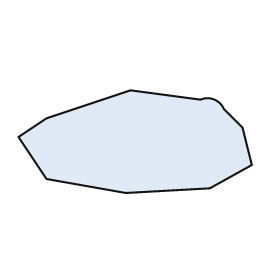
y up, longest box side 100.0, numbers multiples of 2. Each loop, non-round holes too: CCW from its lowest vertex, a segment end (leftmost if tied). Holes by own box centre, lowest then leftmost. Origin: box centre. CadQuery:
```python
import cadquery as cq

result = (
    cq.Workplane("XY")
    .moveTo(-4.0, -22.0)
    .lineTo(32.0, -20.0)
    .lineTo(50.0, -10.0)
    .lineTo(46.0, 6.0)
    .lineTo(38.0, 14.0)
    .threePointArc((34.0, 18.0), (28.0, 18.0))
    .lineTo(-2.0, 22.0)
    .lineTo(-38.0, 10.0)
    .lineTo(-50.0, 2.0)
    .lineTo(-38.0, -16.0)
    .close()
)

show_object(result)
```